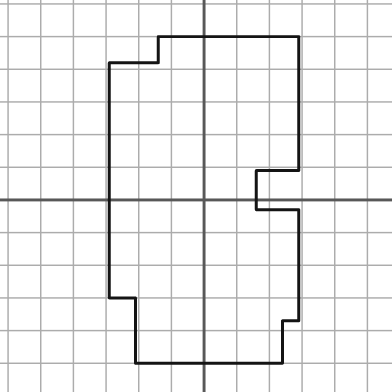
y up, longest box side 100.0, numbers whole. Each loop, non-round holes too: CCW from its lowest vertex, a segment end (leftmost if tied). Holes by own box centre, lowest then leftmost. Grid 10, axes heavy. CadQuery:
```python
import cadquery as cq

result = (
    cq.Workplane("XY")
    .moveTo(-21.0, -50.0)
    .lineTo(24.0, -50.0)
    .lineTo(24.0, -37.0)
    .lineTo(29.0, -37.0)
    .lineTo(29.0, -3.0)
    .lineTo(16.0, -3.0)
    .lineTo(16.0, 9.0)
    .lineTo(29.0, 9.0)
    .lineTo(29.0, 50.0)
    .lineTo(-14.0, 50.0)
    .lineTo(-14.0, 42.0)
    .lineTo(-29.0, 42.0)
    .lineTo(-29.0, -30.0)
    .lineTo(-21.0, -30.0)
    .close()
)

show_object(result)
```